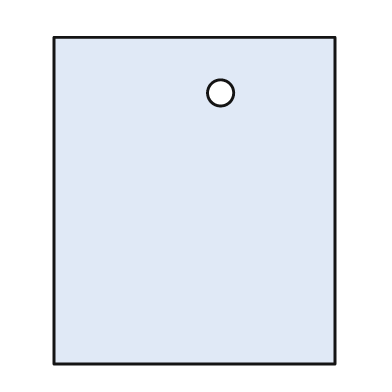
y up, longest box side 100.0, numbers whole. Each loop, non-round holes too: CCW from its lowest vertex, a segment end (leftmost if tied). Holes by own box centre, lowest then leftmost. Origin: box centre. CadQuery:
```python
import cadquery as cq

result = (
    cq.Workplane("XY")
    .moveTo(-43.0, -50.0)
    .lineTo(43.0, -50.0)
    .lineTo(43.0, 50.0)
    .lineTo(-43.0, 50.0)
    .close()
    .moveTo(8.0, 33.0)
    .circle(4.0)
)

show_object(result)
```